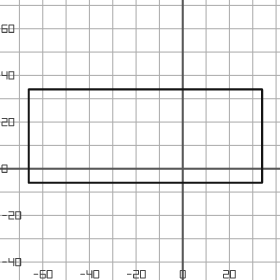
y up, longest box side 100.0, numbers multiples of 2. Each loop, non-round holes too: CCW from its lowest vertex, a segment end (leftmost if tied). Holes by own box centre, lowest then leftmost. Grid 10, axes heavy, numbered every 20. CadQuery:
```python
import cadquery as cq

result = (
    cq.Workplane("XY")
    .moveTo(-66.0, -6.0)
    .lineTo(34.0, -6.0)
    .lineTo(34.0, 34.0)
    .lineTo(-66.0, 34.0)
    .close()
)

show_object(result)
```